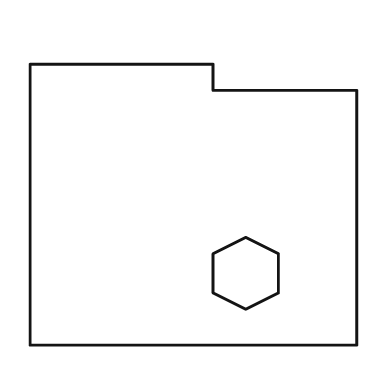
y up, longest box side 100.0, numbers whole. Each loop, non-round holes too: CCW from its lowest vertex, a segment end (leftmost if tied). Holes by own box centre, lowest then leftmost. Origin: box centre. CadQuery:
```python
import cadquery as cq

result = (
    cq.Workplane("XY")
    .moveTo(-50.0, -43.0)
    .lineTo(50.0, -43.0)
    .lineTo(50.0, 35.0)
    .lineTo(6.0, 35.0)
    .lineTo(6.0, 43.0)
    .lineTo(-50.0, 43.0)
    .close()
    .moveTo(16.0, -32.0)
    .lineTo(26.0, -27.0)
    .lineTo(26.0, -15.0)
    .lineTo(16.0, -10.0)
    .lineTo(6.0, -15.0)
    .lineTo(6.0, -27.0)
    .close()
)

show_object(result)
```